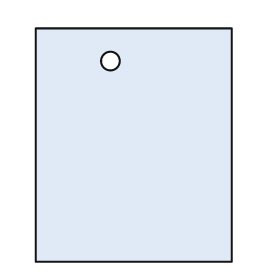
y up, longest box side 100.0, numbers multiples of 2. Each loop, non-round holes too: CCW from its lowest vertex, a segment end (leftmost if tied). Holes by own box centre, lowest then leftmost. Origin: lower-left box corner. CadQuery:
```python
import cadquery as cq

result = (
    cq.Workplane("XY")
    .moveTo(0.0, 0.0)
    .lineTo(84.0, 0.0)
    .lineTo(84.0, 100.0)
    .lineTo(0.0, 100.0)
    .close()
    .moveTo(32.0, 86.0)
    .circle(4.0)
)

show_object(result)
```